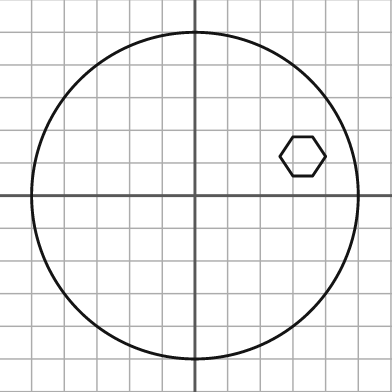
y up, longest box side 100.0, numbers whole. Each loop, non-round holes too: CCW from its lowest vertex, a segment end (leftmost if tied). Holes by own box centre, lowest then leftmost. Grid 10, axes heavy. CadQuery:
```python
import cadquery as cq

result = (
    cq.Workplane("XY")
    .moveTo(0.0, 0.0)
    .circle(50.0)
    .moveTo(30.0, 6.0)
    .lineTo(36.0, 6.0)
    .lineTo(40.0, 12.0)
    .lineTo(36.0, 18.0)
    .lineTo(30.0, 18.0)
    .lineTo(26.0, 12.0)
    .close()
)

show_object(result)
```